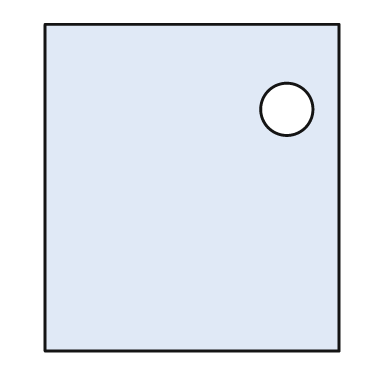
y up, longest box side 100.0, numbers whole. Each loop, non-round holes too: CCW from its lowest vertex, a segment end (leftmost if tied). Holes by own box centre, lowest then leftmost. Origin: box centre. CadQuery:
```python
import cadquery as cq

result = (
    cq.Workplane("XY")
    .moveTo(-45.0, -50.0)
    .lineTo(45.0, -50.0)
    .lineTo(45.0, 50.0)
    .lineTo(-45.0, 50.0)
    .close()
    .moveTo(29.0, 24.0)
    .circle(8.0)
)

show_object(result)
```